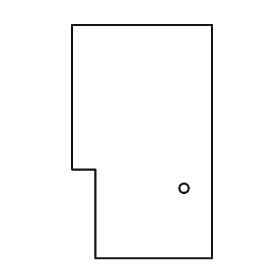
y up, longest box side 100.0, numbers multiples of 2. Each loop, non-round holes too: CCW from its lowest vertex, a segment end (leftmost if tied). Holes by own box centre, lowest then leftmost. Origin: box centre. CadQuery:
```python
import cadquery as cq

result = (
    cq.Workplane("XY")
    .moveTo(-20.0, -50.0)
    .lineTo(30.0, -50.0)
    .lineTo(30.0, 50.0)
    .lineTo(-30.0, 50.0)
    .lineTo(-30.0, -12.0)
    .lineTo(-20.0, -12.0)
    .close()
    .moveTo(18.0, -20.0)
    .circle(2.0)
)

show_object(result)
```